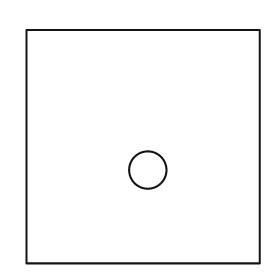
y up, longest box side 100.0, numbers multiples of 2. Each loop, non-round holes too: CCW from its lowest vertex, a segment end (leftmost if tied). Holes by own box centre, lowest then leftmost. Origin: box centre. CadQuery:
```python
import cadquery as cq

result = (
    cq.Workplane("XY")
    .moveTo(-50.0, -50.0)
    .lineTo(50.0, -50.0)
    .lineTo(50.0, 50.0)
    .lineTo(-50.0, 50.0)
    .close()
    .moveTo(2.0, -10.0)
    .circle(8.0)
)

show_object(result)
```